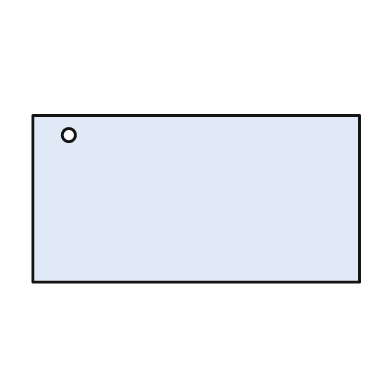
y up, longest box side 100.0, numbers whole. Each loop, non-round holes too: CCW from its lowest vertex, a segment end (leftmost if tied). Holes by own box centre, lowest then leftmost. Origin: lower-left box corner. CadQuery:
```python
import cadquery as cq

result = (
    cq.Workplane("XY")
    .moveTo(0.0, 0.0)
    .lineTo(100.0, 0.0)
    .lineTo(100.0, 51.0)
    .lineTo(0.0, 51.0)
    .close()
    .moveTo(11.0, 45.0)
    .circle(2.0)
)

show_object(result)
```